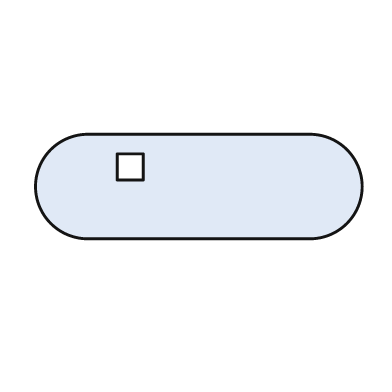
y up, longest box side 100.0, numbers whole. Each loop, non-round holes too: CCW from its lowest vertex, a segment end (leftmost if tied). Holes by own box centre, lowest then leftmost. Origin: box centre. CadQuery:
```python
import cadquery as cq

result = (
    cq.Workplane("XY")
    .moveTo(-34.0, -16.0)
    .lineTo(34.0, -16.0)
    .threePointArc((50.0, 0.0), (34.0, 16.0))
    .lineTo(-34.0, 16.0)
    .threePointArc((-50.0, 0.0), (-34.0, -16.0))
    .close()
    .moveTo(-25.0, 2.0)
    .lineTo(-17.0, 2.0)
    .lineTo(-17.0, 10.0)
    .lineTo(-25.0, 10.0)
    .close()
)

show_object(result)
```